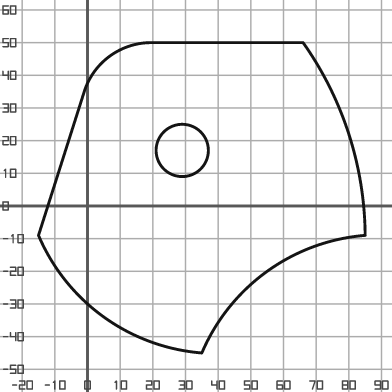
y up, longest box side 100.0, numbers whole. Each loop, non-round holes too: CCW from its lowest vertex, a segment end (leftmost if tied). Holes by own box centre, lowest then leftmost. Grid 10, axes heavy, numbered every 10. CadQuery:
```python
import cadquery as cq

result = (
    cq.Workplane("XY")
    .moveTo(35.0, -45.0)
    .threePointArc((55.0, -20.0), (85.0, -9.0))
    .threePointArc((80.0, 22.0), (66.0, 50.0))
    .lineTo(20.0, 50.0)
    .threePointArc((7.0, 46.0), (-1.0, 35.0))
    .lineTo(-15.0, -9.0)
    .threePointArc((5.0, -34.0), (35.0, -45.0))
    .close()
    .moveTo(29.0, 17.0)
    .circle(8.0)
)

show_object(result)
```